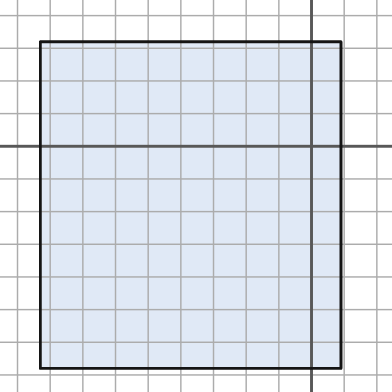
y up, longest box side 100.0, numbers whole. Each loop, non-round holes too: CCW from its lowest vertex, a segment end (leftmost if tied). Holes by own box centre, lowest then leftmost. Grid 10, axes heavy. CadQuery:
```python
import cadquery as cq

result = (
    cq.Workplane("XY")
    .moveTo(-83.0, -68.0)
    .lineTo(9.0, -68.0)
    .lineTo(9.0, 32.0)
    .lineTo(-83.0, 32.0)
    .close()
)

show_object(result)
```